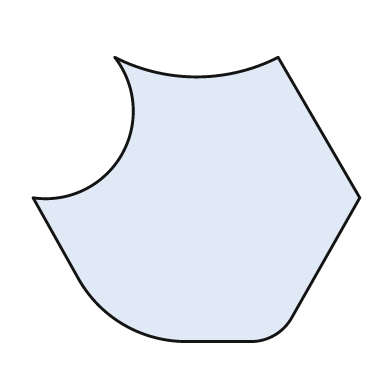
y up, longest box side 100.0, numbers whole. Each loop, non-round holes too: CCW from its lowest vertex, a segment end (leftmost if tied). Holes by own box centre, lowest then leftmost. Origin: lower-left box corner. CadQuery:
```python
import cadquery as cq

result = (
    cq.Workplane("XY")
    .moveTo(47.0, 0.0)
    .lineTo(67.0, 0.0)
    .threePointArc((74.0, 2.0), (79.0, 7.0))
    .lineTo(100.0, 44.0)
    .lineTo(75.0, 87.0)
    .threePointArc((50.0, 81.0), (25.0, 87.0))
    .threePointArc((27.0, 57.0), (0.0, 44.0))
    .lineTo(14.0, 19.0)
    .threePointArc((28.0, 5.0), (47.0, 0.0))
    .close()
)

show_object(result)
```